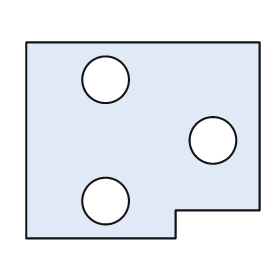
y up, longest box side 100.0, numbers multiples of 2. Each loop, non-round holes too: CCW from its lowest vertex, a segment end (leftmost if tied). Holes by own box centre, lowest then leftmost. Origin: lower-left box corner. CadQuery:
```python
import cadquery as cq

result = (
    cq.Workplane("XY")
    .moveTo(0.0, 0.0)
    .lineTo(64.0, 0.0)
    .lineTo(64.0, 12.0)
    .lineTo(100.0, 12.0)
    .lineTo(100.0, 84.0)
    .lineTo(0.0, 84.0)
    .close()
    .moveTo(34.0, 16.0)
    .circle(10.0)
    .moveTo(80.0, 42.0)
    .circle(10.0)
    .moveTo(34.0, 68.0)
    .circle(10.0)
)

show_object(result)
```